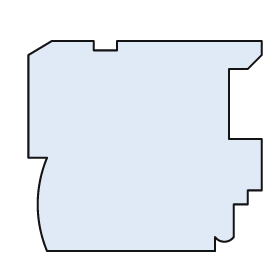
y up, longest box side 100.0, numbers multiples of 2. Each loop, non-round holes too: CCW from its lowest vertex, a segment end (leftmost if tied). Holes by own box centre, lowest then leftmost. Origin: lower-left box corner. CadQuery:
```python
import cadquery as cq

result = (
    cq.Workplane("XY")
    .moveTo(8.0, 0.0)
    .lineTo(80.0, 0.0)
    .lineTo(80.0, 6.0)
    .threePointArc((84.0, 4.0), (88.0, 6.0))
    .lineTo(88.0, 20.0)
    .lineTo(94.0, 20.0)
    .lineTo(94.0, 26.0)
    .lineTo(100.0, 26.0)
    .lineTo(100.0, 48.0)
    .lineTo(86.0, 48.0)
    .lineTo(86.0, 78.0)
    .lineTo(94.0, 78.0)
    .lineTo(100.0, 84.0)
    .lineTo(100.0, 90.0)
    .lineTo(38.0, 90.0)
    .lineTo(38.0, 86.0)
    .lineTo(28.0, 86.0)
    .lineTo(28.0, 90.0)
    .lineTo(10.0, 90.0)
    .lineTo(0.0, 84.0)
    .lineTo(0.0, 40.0)
    .lineTo(8.0, 40.0)
    .threePointArc((4.0, 20.0), (8.0, 0.0))
    .close()
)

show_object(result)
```